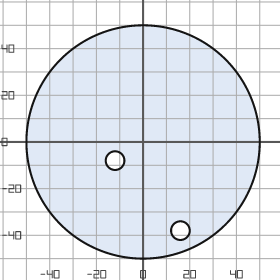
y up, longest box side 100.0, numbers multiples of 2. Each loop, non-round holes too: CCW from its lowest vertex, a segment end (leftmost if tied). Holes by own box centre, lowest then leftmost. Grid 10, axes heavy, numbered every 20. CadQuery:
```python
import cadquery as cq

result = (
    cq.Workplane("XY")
    .moveTo(0.0, 0.0)
    .circle(50.0)
    .moveTo(16.0, -38.0)
    .circle(4.0)
    .moveTo(-12.0, -8.0)
    .circle(4.0)
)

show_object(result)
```